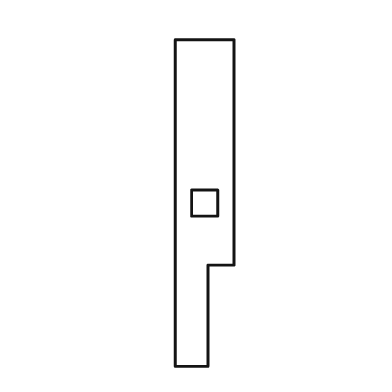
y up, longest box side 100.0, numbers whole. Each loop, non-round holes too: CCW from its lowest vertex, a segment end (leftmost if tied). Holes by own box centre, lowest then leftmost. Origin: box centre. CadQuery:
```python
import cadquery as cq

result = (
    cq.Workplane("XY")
    .moveTo(-9.0, -50.0)
    .lineTo(1.0, -50.0)
    .lineTo(1.0, -19.0)
    .lineTo(9.0, -19.0)
    .lineTo(9.0, 50.0)
    .lineTo(-9.0, 50.0)
    .close()
    .moveTo(-4.0, -4.0)
    .lineTo(4.0, -4.0)
    .lineTo(4.0, 4.0)
    .lineTo(-4.0, 4.0)
    .close()
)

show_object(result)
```